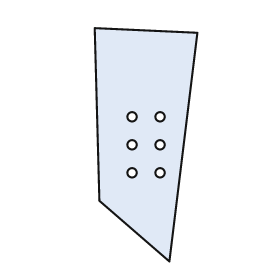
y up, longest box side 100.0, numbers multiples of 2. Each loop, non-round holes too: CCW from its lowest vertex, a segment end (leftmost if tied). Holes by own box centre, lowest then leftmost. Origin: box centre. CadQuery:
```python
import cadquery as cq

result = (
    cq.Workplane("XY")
    .moveTo(10.0, -50.0)
    .lineTo(22.0, 48.0)
    .lineTo(-22.0, 50.0)
    .lineTo(-20.0, -24.0)
    .close()
    .moveTo(-6.0, -12.0)
    .circle(2.0)
    .moveTo(6.0, -12.0)
    .circle(2.0)
    .moveTo(-6.0, 0.0)
    .circle(2.0)
    .moveTo(6.0, 0.0)
    .circle(2.0)
    .moveTo(-6.0, 12.0)
    .circle(2.0)
    .moveTo(6.0, 12.0)
    .circle(2.0)
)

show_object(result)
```